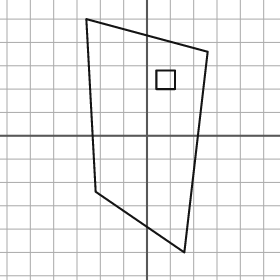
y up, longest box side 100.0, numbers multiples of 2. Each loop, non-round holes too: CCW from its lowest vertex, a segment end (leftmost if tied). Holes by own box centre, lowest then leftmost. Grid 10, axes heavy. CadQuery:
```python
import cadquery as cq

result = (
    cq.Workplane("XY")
    .moveTo(16.0, -50.0)
    .lineTo(26.0, 36.0)
    .lineTo(-26.0, 50.0)
    .lineTo(-22.0, -24.0)
    .close()
    .moveTo(4.0, 20.0)
    .lineTo(12.0, 20.0)
    .lineTo(12.0, 28.0)
    .lineTo(4.0, 28.0)
    .close()
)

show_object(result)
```